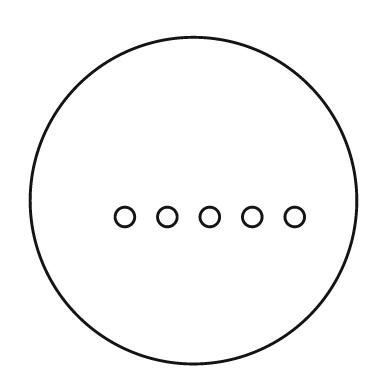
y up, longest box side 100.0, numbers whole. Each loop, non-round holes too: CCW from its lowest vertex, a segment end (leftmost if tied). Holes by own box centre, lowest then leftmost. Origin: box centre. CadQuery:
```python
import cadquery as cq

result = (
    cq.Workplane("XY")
    .moveTo(0.0, 0.0)
    .circle(50.0)
    .moveTo(-21.0, -5.0)
    .circle(3.0)
    .moveTo(-8.0, -5.0)
    .circle(3.0)
    .moveTo(5.0, -5.0)
    .circle(3.0)
    .moveTo(18.0, -5.0)
    .circle(3.0)
    .moveTo(31.0, -5.0)
    .circle(3.0)
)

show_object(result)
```